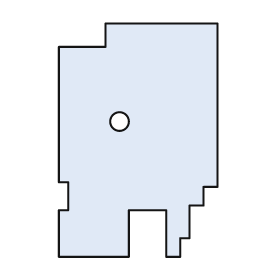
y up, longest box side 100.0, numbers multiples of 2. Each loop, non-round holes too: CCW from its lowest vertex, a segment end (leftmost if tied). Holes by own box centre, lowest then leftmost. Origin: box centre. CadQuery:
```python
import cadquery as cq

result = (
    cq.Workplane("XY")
    .moveTo(-34.0, -50.0)
    .lineTo(-4.0, -50.0)
    .lineTo(-4.0, -30.0)
    .lineTo(12.0, -30.0)
    .lineTo(12.0, -50.0)
    .lineTo(18.0, -50.0)
    .lineTo(18.0, -42.0)
    .lineTo(22.0, -42.0)
    .lineTo(22.0, -28.0)
    .lineTo(28.0, -28.0)
    .lineTo(28.0, -20.0)
    .lineTo(34.0, -20.0)
    .lineTo(34.0, 50.0)
    .lineTo(-14.0, 50.0)
    .lineTo(-14.0, 40.0)
    .lineTo(-34.0, 40.0)
    .lineTo(-34.0, -18.0)
    .lineTo(-30.0, -18.0)
    .lineTo(-30.0, -30.0)
    .lineTo(-34.0, -30.0)
    .close()
    .moveTo(-8.0, 8.0)
    .circle(4.0)
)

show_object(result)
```